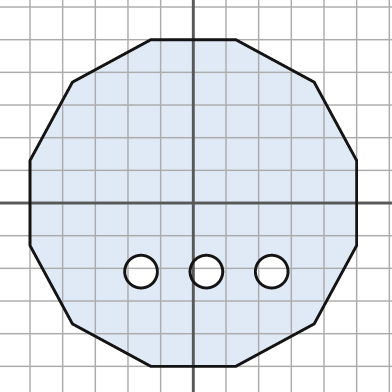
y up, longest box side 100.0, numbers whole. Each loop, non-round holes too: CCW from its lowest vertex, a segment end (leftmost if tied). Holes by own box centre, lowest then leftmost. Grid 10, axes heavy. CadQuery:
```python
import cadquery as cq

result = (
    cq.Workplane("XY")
    .moveTo(-13.0, -50.0)
    .lineTo(13.0, -50.0)
    .lineTo(37.0, -37.0)
    .lineTo(50.0, -13.0)
    .lineTo(50.0, 13.0)
    .lineTo(37.0, 37.0)
    .lineTo(13.0, 50.0)
    .lineTo(-13.0, 50.0)
    .lineTo(-37.0, 37.0)
    .lineTo(-50.0, 13.0)
    .lineTo(-50.0, -13.0)
    .lineTo(-37.0, -37.0)
    .close()
    .moveTo(-16.0, -21.0)
    .circle(5.0)
    .moveTo(4.0, -21.0)
    .circle(5.0)
    .moveTo(24.0, -21.0)
    .circle(5.0)
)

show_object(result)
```